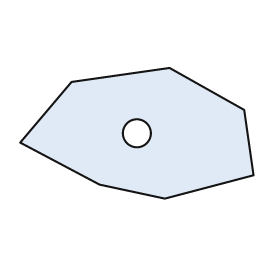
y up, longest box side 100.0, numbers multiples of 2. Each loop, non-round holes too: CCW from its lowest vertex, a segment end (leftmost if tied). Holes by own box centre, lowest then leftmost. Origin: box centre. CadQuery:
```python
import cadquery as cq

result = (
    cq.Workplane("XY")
    .moveTo(12.0, -28.0)
    .lineTo(50.0, -18.0)
    .lineTo(46.0, 10.0)
    .lineTo(14.0, 28.0)
    .lineTo(-28.0, 22.0)
    .lineTo(-50.0, -4.0)
    .lineTo(-16.0, -22.0)
    .close()
    .moveTo(0.0, 0.0)
    .circle(6.0)
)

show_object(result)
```